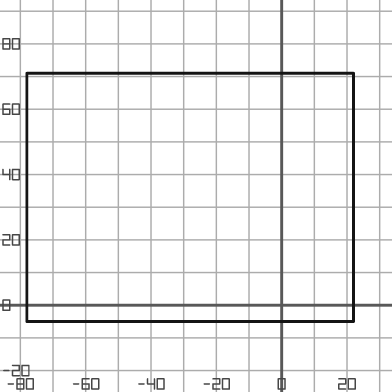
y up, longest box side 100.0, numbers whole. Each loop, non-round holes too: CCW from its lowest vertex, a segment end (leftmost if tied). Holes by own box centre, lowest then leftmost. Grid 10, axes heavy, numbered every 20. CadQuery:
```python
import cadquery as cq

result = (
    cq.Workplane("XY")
    .moveTo(-78.0, -5.0)
    .lineTo(22.0, -5.0)
    .lineTo(22.0, 71.0)
    .lineTo(-78.0, 71.0)
    .close()
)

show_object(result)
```